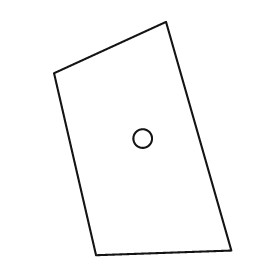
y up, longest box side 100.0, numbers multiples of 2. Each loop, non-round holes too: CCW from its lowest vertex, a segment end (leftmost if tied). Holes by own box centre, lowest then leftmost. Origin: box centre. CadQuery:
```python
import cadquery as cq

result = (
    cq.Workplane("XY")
    .moveTo(-20.0, -50.0)
    .lineTo(38.0, -48.0)
    .lineTo(10.0, 50.0)
    .lineTo(-38.0, 28.0)
    .close()
    .moveTo(0.0, 0.0)
    .circle(4.0)
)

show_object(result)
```